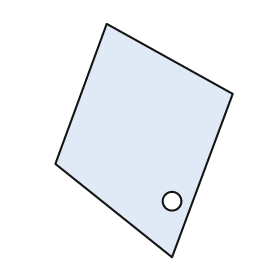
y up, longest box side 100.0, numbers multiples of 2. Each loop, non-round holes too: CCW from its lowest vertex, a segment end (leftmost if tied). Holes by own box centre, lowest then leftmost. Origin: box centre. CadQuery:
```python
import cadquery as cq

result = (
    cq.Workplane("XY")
    .moveTo(12.0, -50.0)
    .lineTo(38.0, 20.0)
    .lineTo(-16.0, 50.0)
    .lineTo(-38.0, -10.0)
    .close()
    .moveTo(12.0, -26.0)
    .circle(4.0)
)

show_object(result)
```